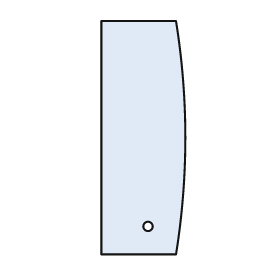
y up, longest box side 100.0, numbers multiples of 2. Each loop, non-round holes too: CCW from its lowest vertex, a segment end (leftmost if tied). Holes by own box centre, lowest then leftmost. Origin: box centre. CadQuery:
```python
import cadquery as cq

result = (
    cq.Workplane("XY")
    .moveTo(-18.0, -50.0)
    .lineTo(14.0, -50.0)
    .threePointArc((18.0, 0.0), (14.0, 50.0))
    .lineTo(-18.0, 50.0)
    .close()
    .moveTo(2.0, -38.0)
    .circle(2.0)
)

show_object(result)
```